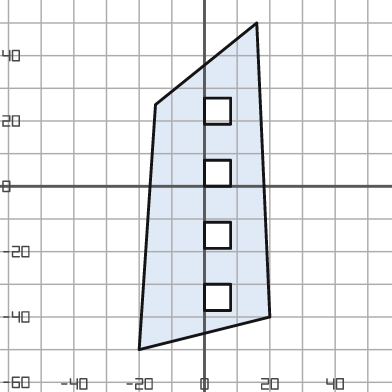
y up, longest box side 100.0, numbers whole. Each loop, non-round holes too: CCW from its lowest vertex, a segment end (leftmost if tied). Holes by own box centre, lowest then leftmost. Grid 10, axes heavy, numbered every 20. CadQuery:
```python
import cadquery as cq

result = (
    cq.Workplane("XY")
    .moveTo(-20.0, -50.0)
    .lineTo(20.0, -40.0)
    .lineTo(16.0, 50.0)
    .lineTo(-15.0, 25.0)
    .close()
    .moveTo(0.0, -38.0)
    .lineTo(8.0, -38.0)
    .lineTo(8.0, -30.0)
    .lineTo(0.0, -30.0)
    .close()
    .moveTo(0.0, -19.0)
    .lineTo(8.0, -19.0)
    .lineTo(8.0, -11.0)
    .lineTo(0.0, -11.0)
    .close()
    .moveTo(0.0, 0.0)
    .lineTo(8.0, 0.0)
    .lineTo(8.0, 8.0)
    .lineTo(0.0, 8.0)
    .close()
    .moveTo(0.0, 19.0)
    .lineTo(8.0, 19.0)
    .lineTo(8.0, 27.0)
    .lineTo(0.0, 27.0)
    .close()
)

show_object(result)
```